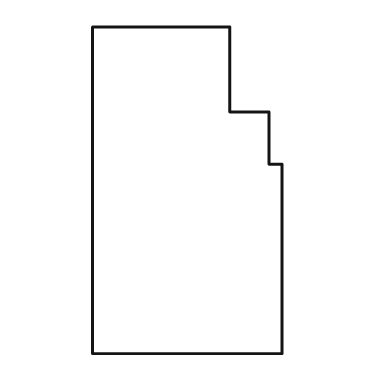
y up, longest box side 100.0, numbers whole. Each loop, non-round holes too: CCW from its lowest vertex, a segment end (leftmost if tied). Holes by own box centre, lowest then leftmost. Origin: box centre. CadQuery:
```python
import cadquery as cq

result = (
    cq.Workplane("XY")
    .moveTo(-29.0, -50.0)
    .lineTo(29.0, -50.0)
    .lineTo(29.0, 8.0)
    .lineTo(25.0, 8.0)
    .lineTo(25.0, 24.0)
    .lineTo(13.0, 24.0)
    .lineTo(13.0, 50.0)
    .lineTo(-29.0, 50.0)
    .close()
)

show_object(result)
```